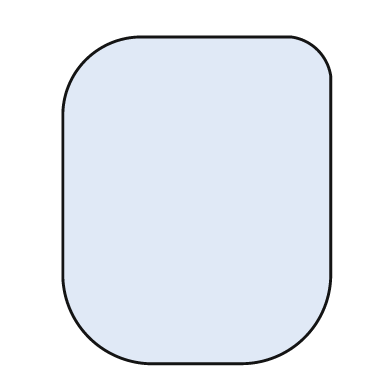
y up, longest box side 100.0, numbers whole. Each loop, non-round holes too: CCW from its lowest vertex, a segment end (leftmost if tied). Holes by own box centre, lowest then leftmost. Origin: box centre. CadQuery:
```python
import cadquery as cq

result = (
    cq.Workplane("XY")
    .moveTo(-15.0, -50.0)
    .lineTo(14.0, -50.0)
    .threePointArc((33.0, -42.0), (41.0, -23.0))
    .lineTo(41.0, 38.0)
    .threePointArc((37.0, 46.0), (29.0, 50.0))
    .lineTo(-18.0, 50.0)
    .threePointArc((-34.0, 43.0), (-41.0, 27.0))
    .lineTo(-41.0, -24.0)
    .threePointArc((-33.0, -42.0), (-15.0, -50.0))
    .close()
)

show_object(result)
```